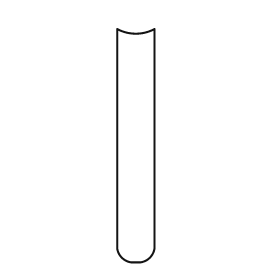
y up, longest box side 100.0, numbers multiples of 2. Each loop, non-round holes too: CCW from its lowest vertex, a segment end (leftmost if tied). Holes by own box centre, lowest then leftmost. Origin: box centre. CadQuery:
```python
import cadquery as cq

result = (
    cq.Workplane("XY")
    .moveTo(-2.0, -50.0)
    .lineTo(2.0, -50.0)
    .threePointArc((6.0, -48.0), (8.0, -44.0))
    .lineTo(8.0, 50.0)
    .threePointArc((0.0, 48.0), (-8.0, 50.0))
    .lineTo(-8.0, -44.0)
    .threePointArc((-6.0, -48.0), (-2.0, -50.0))
    .close()
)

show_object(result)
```